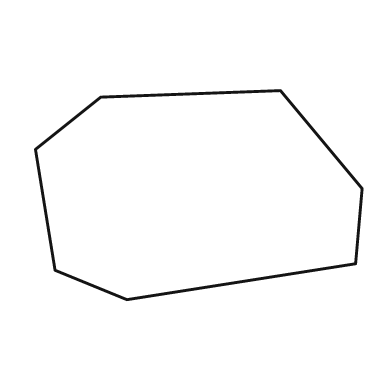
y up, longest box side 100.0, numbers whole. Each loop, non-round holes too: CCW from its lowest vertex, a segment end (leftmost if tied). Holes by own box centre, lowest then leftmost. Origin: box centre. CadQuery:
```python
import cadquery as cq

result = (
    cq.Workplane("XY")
    .moveTo(-22.0, -32.0)
    .lineTo(48.0, -21.0)
    .lineTo(50.0, 2.0)
    .lineTo(25.0, 32.0)
    .lineTo(-30.0, 30.0)
    .lineTo(-50.0, 14.0)
    .lineTo(-44.0, -23.0)
    .close()
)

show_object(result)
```